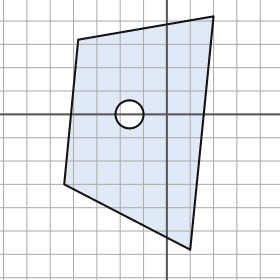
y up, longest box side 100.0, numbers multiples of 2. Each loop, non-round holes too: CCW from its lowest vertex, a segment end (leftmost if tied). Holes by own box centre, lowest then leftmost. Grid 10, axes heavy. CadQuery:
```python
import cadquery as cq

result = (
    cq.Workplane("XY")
    .moveTo(10.0, -58.0)
    .lineTo(20.0, 42.0)
    .lineTo(-38.0, 32.0)
    .lineTo(-44.0, -30.0)
    .close()
    .moveTo(-16.0, 0.0)
    .circle(6.0)
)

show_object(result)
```